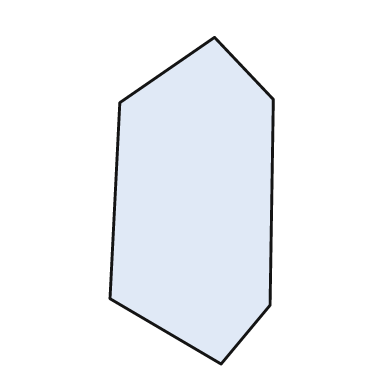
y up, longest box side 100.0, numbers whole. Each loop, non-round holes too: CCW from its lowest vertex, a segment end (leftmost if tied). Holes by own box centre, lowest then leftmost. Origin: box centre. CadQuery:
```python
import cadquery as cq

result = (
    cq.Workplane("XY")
    .moveTo(9.0, -50.0)
    .lineTo(24.0, -32.0)
    .lineTo(25.0, 31.0)
    .lineTo(7.0, 50.0)
    .lineTo(-22.0, 30.0)
    .lineTo(-25.0, -30.0)
    .close()
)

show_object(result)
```